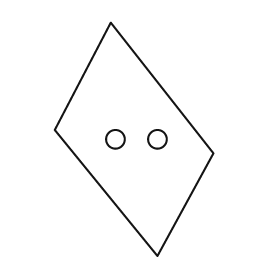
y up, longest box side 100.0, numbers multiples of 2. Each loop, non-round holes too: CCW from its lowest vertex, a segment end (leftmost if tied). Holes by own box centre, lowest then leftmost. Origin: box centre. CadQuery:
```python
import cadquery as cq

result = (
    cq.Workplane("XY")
    .moveTo(10.0, -50.0)
    .lineTo(34.0, -6.0)
    .lineTo(-10.0, 50.0)
    .lineTo(-34.0, 4.0)
    .close()
    .moveTo(-8.0, 0.0)
    .circle(4.0)
    .moveTo(10.0, 0.0)
    .circle(4.0)
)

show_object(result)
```